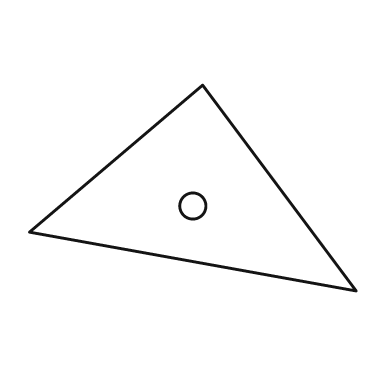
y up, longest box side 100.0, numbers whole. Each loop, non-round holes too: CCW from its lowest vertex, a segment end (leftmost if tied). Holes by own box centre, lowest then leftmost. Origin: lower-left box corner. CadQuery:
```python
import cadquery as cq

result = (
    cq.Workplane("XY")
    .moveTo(100.0, 0.0)
    .lineTo(53.0, 63.0)
    .lineTo(0.0, 18.0)
    .close()
    .moveTo(50.0, 26.0)
    .circle(4.0)
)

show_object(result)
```